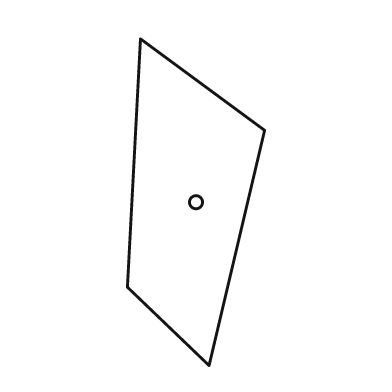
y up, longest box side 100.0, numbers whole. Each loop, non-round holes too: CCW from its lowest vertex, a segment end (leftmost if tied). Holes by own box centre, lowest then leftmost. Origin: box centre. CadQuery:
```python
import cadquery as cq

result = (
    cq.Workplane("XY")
    .moveTo(4.0, -50.0)
    .lineTo(21.0, 22.0)
    .lineTo(-17.0, 50.0)
    .lineTo(-21.0, -26.0)
    .close()
    .moveTo(0.0, 0.0)
    .circle(2.0)
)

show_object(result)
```